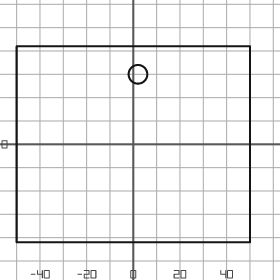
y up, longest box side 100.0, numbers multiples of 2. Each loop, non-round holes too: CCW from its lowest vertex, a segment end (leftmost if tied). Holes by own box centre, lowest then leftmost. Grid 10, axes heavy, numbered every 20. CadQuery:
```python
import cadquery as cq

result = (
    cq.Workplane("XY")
    .moveTo(-50.0, -42.0)
    .lineTo(50.0, -42.0)
    .lineTo(50.0, 42.0)
    .lineTo(-50.0, 42.0)
    .close()
    .moveTo(2.0, 30.0)
    .circle(4.0)
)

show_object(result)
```